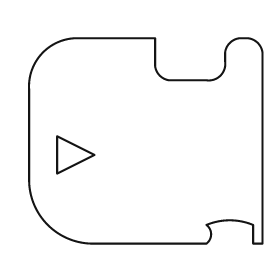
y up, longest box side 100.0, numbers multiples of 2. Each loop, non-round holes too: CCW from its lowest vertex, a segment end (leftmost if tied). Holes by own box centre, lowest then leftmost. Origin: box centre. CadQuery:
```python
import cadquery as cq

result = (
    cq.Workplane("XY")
    .moveTo(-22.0, -44.0)
    .lineTo(26.0, -44.0)
    .threePointArc((28.0, -40.0), (26.0, -36.0))
    .threePointArc((36.0, -34.0), (46.0, -36.0))
    .lineTo(46.0, -44.0)
    .lineTo(50.0, -44.0)
    .lineTo(50.0, 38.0)
    .threePointArc((48.0, 42.0), (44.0, 44.0))
    .lineTo(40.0, 44.0)
    .threePointArc((36.0, 42.0), (34.0, 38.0))
    .lineTo(34.0, 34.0)
    .threePointArc((32.0, 28.0), (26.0, 26.0))
    .lineTo(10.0, 26.0)
    .threePointArc((6.0, 28.0), (4.0, 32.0))
    .lineTo(4.0, 44.0)
    .lineTo(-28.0, 44.0)
    .threePointArc((-44.0, 38.0), (-50.0, 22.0))
    .lineTo(-50.0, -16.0)
    .threePointArc((-42.0, -36.0), (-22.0, -44.0))
    .close()
    .moveTo(-38.0, -14.0)
    .lineTo(-22.0, -6.0)
    .lineTo(-38.0, 2.0)
    .close()
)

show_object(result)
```